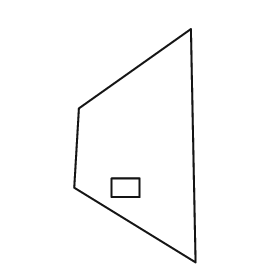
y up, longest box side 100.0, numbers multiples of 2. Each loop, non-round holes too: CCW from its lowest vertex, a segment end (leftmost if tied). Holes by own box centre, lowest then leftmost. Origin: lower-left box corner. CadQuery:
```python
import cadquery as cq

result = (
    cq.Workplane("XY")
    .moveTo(52.0, 0.0)
    .lineTo(50.0, 100.0)
    .lineTo(2.0, 66.0)
    .lineTo(0.0, 32.0)
    .close()
    .moveTo(16.0, 28.0)
    .lineTo(28.0, 28.0)
    .lineTo(28.0, 36.0)
    .lineTo(16.0, 36.0)
    .close()
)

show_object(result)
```